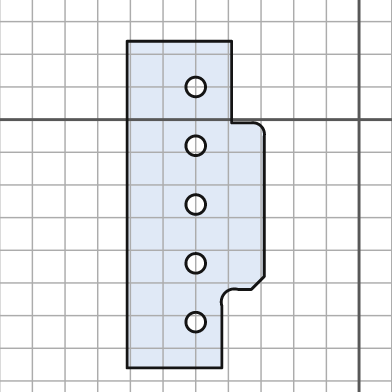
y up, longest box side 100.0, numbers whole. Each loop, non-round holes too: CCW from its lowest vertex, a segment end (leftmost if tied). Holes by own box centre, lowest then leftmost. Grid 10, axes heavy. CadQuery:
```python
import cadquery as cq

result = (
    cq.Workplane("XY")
    .moveTo(-71.0, -76.0)
    .lineTo(-42.0, -76.0)
    .lineTo(-42.0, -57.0)
    .threePointArc((-41.0, -53.0), (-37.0, -52.0))
    .lineTo(-33.0, -52.0)
    .lineTo(-29.0, -48.0)
    .lineTo(-29.0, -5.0)
    .threePointArc((-30.0, -2.0), (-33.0, -1.0))
    .lineTo(-39.0, -1.0)
    .lineTo(-39.0, 24.0)
    .lineTo(-71.0, 24.0)
    .close()
    .moveTo(-50.0, -62.0)
    .circle(3.0)
    .moveTo(-50.0, -44.0)
    .circle(3.0)
    .moveTo(-50.0, -26.0)
    .circle(3.0)
    .moveTo(-50.0, -8.0)
    .circle(3.0)
    .moveTo(-50.0, 10.0)
    .circle(3.0)
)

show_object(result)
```